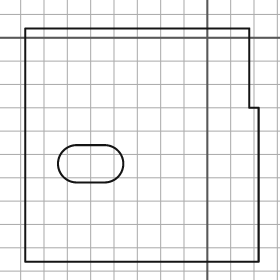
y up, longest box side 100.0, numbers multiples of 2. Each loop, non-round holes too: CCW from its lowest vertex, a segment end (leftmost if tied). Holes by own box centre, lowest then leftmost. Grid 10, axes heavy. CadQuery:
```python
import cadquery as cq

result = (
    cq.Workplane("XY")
    .moveTo(-78.0, -96.0)
    .lineTo(22.0, -96.0)
    .lineTo(22.0, -30.0)
    .lineTo(18.0, -30.0)
    .lineTo(18.0, 4.0)
    .lineTo(-78.0, 4.0)
    .close()
    .moveTo(-56.0, -62.0)
    .lineTo(-44.0, -62.0)
    .threePointArc((-36.0, -54.0), (-44.0, -46.0))
    .lineTo(-56.0, -46.0)
    .threePointArc((-64.0, -54.0), (-56.0, -62.0))
    .close()
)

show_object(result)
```